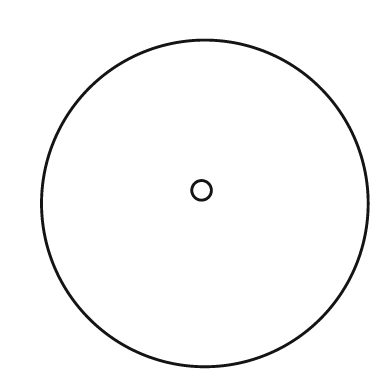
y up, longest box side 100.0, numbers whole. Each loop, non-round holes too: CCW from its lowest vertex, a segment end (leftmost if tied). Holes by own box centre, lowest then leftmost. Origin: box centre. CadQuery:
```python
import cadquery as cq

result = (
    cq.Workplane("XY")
    .moveTo(0.0, 0.0)
    .circle(50.0)
    .moveTo(-1.0, 4.0)
    .circle(3.0)
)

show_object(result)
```